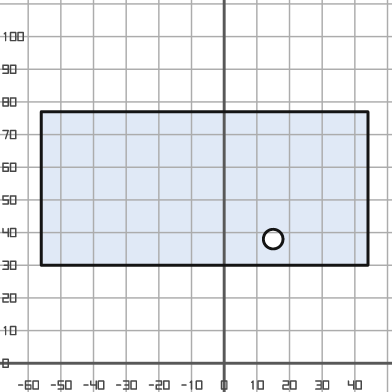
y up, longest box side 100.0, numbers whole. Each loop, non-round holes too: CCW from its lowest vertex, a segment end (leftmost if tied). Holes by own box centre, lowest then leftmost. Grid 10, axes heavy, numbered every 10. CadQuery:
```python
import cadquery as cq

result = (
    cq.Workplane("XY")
    .moveTo(-56.0, 30.0)
    .lineTo(44.0, 30.0)
    .lineTo(44.0, 77.0)
    .lineTo(-56.0, 77.0)
    .close()
    .moveTo(15.0, 38.0)
    .circle(3.0)
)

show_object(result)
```